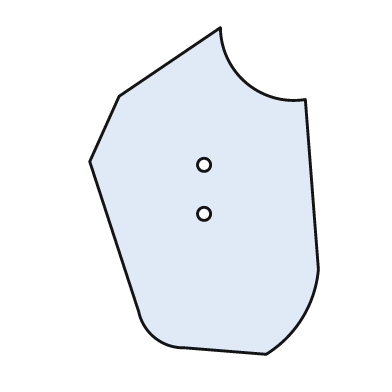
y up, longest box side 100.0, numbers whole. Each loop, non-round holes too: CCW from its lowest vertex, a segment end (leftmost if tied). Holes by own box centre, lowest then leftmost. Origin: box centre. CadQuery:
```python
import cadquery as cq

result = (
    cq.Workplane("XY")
    .moveTo(19.0, -50.0)
    .threePointArc((30.0, -39.0), (35.0, -24.0))
    .lineTo(31.0, 28.0)
    .threePointArc((13.0, 33.0), (5.0, 50.0))
    .lineTo(-26.0, 29.0)
    .lineTo(-35.0, 9.0)
    .lineTo(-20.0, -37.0)
    .threePointArc((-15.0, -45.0), (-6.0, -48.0))
    .close()
    .moveTo(0.0, -7.0)
    .circle(2.0)
    .moveTo(0.0, 8.0)
    .circle(2.0)
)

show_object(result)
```